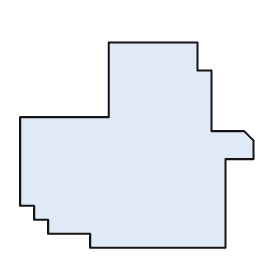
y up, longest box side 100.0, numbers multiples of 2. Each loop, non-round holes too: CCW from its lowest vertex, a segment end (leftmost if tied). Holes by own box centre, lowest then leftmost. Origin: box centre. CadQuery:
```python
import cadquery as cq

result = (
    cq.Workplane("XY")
    .moveTo(-20.0, -44.0)
    .lineTo(38.0, -44.0)
    .lineTo(38.0, -6.0)
    .lineTo(50.0, -6.0)
    .lineTo(50.0, 2.0)
    .lineTo(46.0, 6.0)
    .lineTo(32.0, 6.0)
    .lineTo(32.0, 32.0)
    .lineTo(26.0, 32.0)
    .lineTo(26.0, 44.0)
    .lineTo(-12.0, 44.0)
    .lineTo(-12.0, 12.0)
    .lineTo(-50.0, 12.0)
    .lineTo(-50.0, -26.0)
    .lineTo(-44.0, -26.0)
    .lineTo(-44.0, -32.0)
    .lineTo(-38.0, -32.0)
    .lineTo(-38.0, -38.0)
    .lineTo(-20.0, -38.0)
    .close()
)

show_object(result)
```